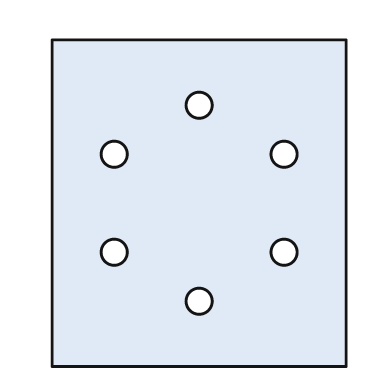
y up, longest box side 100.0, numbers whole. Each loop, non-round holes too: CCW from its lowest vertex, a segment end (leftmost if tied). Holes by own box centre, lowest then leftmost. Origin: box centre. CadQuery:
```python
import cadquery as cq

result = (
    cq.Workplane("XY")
    .moveTo(-45.0, -50.0)
    .lineTo(45.0, -50.0)
    .lineTo(45.0, 50.0)
    .lineTo(-45.0, 50.0)
    .close()
    .moveTo(0.0, -30.0)
    .circle(4.0)
    .moveTo(-26.0, -15.0)
    .circle(4.0)
    .moveTo(26.0, -15.0)
    .circle(4.0)
    .moveTo(-26.0, 15.0)
    .circle(4.0)
    .moveTo(26.0, 15.0)
    .circle(4.0)
    .moveTo(0.0, 30.0)
    .circle(4.0)
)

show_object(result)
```